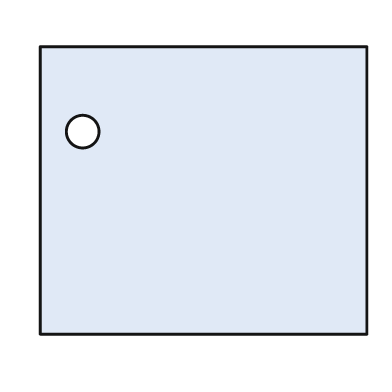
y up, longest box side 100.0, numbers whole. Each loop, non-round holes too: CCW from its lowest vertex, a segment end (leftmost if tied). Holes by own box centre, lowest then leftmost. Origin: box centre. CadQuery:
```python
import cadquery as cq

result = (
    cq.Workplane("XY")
    .moveTo(-50.0, -44.0)
    .lineTo(50.0, -44.0)
    .lineTo(50.0, 44.0)
    .lineTo(-50.0, 44.0)
    .close()
    .moveTo(-37.0, 18.0)
    .circle(5.0)
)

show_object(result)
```